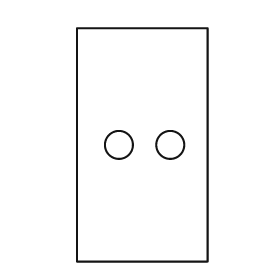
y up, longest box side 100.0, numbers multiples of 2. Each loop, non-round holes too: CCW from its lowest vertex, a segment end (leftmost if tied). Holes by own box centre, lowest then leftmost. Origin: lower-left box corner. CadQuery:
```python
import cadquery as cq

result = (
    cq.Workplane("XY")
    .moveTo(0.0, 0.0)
    .lineTo(56.0, 0.0)
    .lineTo(56.0, 100.0)
    .lineTo(0.0, 100.0)
    .close()
    .moveTo(18.0, 50.0)
    .circle(6.0)
    .moveTo(40.0, 50.0)
    .circle(6.0)
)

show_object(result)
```